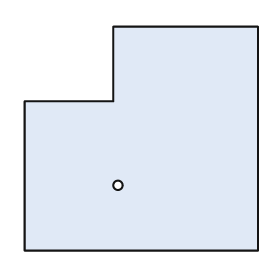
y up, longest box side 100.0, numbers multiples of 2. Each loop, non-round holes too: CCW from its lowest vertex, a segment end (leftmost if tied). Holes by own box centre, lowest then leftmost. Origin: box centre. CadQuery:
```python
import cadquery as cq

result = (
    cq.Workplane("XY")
    .moveTo(-50.0, -48.0)
    .lineTo(50.0, -48.0)
    .lineTo(50.0, 48.0)
    .lineTo(-12.0, 48.0)
    .lineTo(-12.0, 16.0)
    .lineTo(-50.0, 16.0)
    .close()
    .moveTo(-10.0, -20.0)
    .circle(2.0)
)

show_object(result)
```